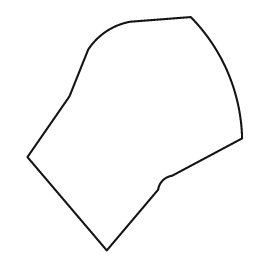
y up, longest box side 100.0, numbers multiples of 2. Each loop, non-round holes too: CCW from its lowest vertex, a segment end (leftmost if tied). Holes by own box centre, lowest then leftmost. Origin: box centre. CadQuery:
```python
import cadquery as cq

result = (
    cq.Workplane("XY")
    .moveTo(-12.0, -50.0)
    .lineTo(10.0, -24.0)
    .threePointArc((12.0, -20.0), (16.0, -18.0))
    .lineTo(46.0, -2.0)
    .threePointArc((40.0, 26.0), (24.0, 50.0))
    .lineTo(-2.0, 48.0)
    .threePointArc((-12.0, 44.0), (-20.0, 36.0))
    .lineTo(-28.0, 16.0)
    .lineTo(-46.0, -10.0)
    .close()
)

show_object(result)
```